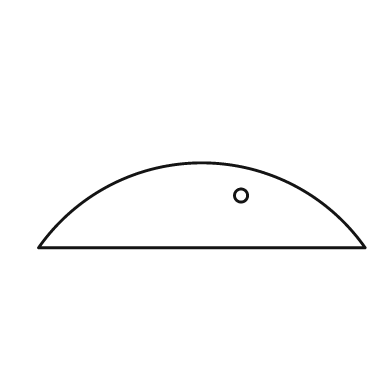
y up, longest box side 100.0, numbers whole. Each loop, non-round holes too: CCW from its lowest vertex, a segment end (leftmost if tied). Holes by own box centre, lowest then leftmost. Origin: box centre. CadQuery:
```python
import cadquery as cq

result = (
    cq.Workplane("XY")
    .moveTo(-50.0, -13.0)
    .lineTo(50.0, -13.0)
    .threePointArc((0.0, 13.0), (-50.0, -13.0))
    .close()
    .moveTo(12.0, 3.0)
    .circle(2.0)
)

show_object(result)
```